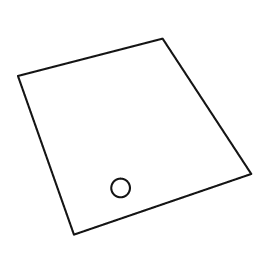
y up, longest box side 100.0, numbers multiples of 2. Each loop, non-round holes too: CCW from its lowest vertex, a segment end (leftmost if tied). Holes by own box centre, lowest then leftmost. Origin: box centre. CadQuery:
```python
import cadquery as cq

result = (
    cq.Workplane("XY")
    .moveTo(-26.0, -42.0)
    .lineTo(50.0, -16.0)
    .lineTo(12.0, 42.0)
    .lineTo(-50.0, 26.0)
    .close()
    .moveTo(-6.0, -22.0)
    .circle(4.0)
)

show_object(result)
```